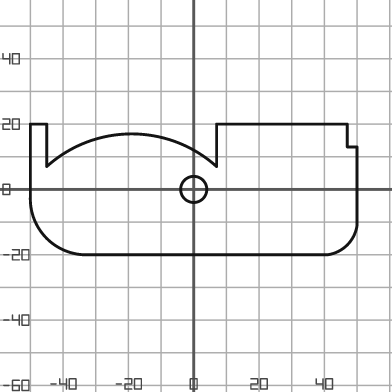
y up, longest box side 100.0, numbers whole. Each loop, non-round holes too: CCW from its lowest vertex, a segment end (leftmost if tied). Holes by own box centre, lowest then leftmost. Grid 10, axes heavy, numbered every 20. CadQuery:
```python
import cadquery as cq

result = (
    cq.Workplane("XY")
    .moveTo(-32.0, -20.0)
    .lineTo(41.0, -20.0)
    .threePointArc((47.0, -17.0), (50.0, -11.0))
    .lineTo(50.0, 13.0)
    .lineTo(47.0, 13.0)
    .lineTo(47.0, 20.0)
    .lineTo(7.0, 20.0)
    .lineTo(7.0, 7.0)
    .threePointArc((-19.0, 17.0), (-45.0, 7.0))
    .lineTo(-45.0, 20.0)
    .lineTo(-50.0, 20.0)
    .lineTo(-50.0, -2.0)
    .threePointArc((-45.0, -15.0), (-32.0, -20.0))
    .close()
    .moveTo(0.0, 0.0)
    .circle(4.0)
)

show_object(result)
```